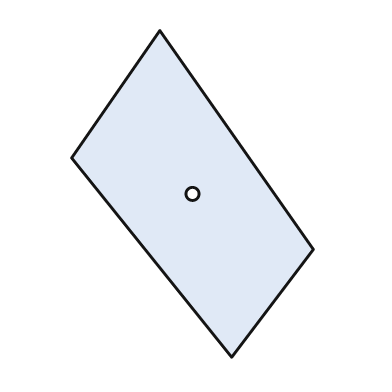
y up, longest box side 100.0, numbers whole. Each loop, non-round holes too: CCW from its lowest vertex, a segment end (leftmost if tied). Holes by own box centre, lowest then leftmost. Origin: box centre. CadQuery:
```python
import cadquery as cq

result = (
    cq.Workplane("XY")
    .moveTo(12.0, -50.0)
    .lineTo(37.0, -17.0)
    .lineTo(-10.0, 50.0)
    .lineTo(-37.0, 11.0)
    .close()
    .moveTo(0.0, 0.0)
    .circle(2.0)
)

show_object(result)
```